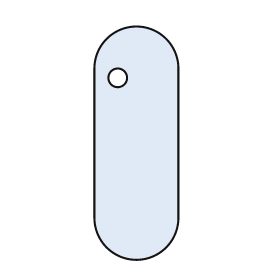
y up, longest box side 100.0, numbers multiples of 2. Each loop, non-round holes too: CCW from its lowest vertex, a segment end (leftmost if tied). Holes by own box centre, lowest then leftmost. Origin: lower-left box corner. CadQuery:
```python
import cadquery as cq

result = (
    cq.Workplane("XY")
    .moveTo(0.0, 18.0)
    .threePointArc((18.0, 0.0), (36.0, 18.0))
    .lineTo(36.0, 82.0)
    .threePointArc((18.0, 100.0), (0.0, 82.0))
    .close()
    .moveTo(10.0, 78.0)
    .circle(4.0)
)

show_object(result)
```